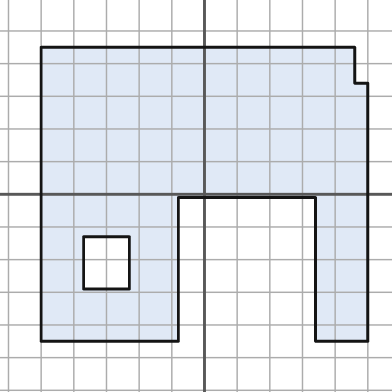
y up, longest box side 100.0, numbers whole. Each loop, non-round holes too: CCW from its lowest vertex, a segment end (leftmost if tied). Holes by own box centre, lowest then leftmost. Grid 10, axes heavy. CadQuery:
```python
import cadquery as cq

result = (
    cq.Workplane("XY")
    .moveTo(-50.0, -45.0)
    .lineTo(-8.0, -45.0)
    .lineTo(-8.0, -1.0)
    .lineTo(34.0, -1.0)
    .lineTo(34.0, -45.0)
    .lineTo(50.0, -45.0)
    .lineTo(50.0, 34.0)
    .lineTo(46.0, 34.0)
    .lineTo(46.0, 45.0)
    .lineTo(-50.0, 45.0)
    .close()
    .moveTo(-37.0, -29.0)
    .lineTo(-23.0, -29.0)
    .lineTo(-23.0, -13.0)
    .lineTo(-37.0, -13.0)
    .close()
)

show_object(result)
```